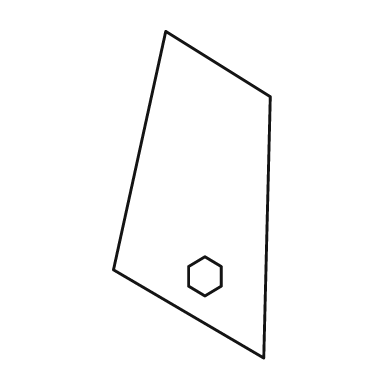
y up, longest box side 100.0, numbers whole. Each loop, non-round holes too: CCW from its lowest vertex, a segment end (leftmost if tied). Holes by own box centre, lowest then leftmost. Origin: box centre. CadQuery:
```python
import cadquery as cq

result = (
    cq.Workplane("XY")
    .moveTo(22.0, -50.0)
    .lineTo(24.0, 30.0)
    .lineTo(-8.0, 50.0)
    .lineTo(-24.0, -23.0)
    .close()
    .moveTo(4.0, -31.0)
    .lineTo(9.0, -28.0)
    .lineTo(9.0, -22.0)
    .lineTo(4.0, -19.0)
    .lineTo(-1.0, -22.0)
    .lineTo(-1.0, -28.0)
    .close()
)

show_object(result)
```